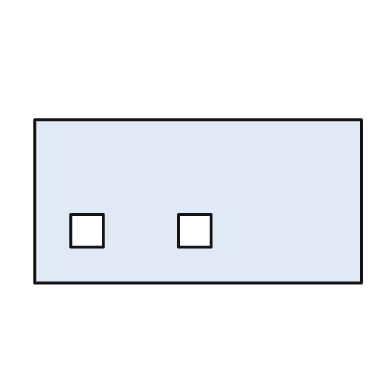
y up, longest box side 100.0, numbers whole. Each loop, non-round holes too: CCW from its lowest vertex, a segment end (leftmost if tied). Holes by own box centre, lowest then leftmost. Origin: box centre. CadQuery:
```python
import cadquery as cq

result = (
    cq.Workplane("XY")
    .moveTo(-50.0, -25.0)
    .lineTo(50.0, -25.0)
    .lineTo(50.0, 25.0)
    .lineTo(-50.0, 25.0)
    .close()
    .moveTo(-39.0, -14.0)
    .lineTo(-29.0, -14.0)
    .lineTo(-29.0, -4.0)
    .lineTo(-39.0, -4.0)
    .close()
    .moveTo(-6.0, -14.0)
    .lineTo(4.0, -14.0)
    .lineTo(4.0, -4.0)
    .lineTo(-6.0, -4.0)
    .close()
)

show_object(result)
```